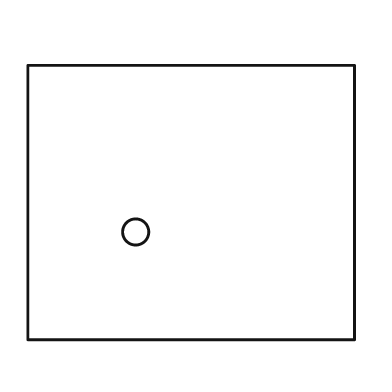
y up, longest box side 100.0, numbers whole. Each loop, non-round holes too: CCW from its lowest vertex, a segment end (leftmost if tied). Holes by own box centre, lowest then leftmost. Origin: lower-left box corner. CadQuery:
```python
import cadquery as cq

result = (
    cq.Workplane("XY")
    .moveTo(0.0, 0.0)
    .lineTo(100.0, 0.0)
    .lineTo(100.0, 84.0)
    .lineTo(0.0, 84.0)
    .close()
    .moveTo(33.0, 33.0)
    .circle(4.0)
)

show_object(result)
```